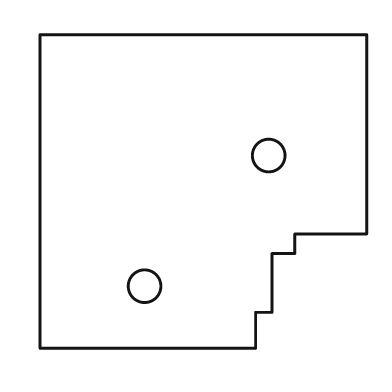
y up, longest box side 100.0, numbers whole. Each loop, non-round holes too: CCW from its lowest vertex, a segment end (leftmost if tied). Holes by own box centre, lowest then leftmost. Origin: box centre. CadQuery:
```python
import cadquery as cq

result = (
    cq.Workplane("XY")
    .moveTo(-50.0, -48.0)
    .lineTo(16.0, -48.0)
    .lineTo(16.0, -37.0)
    .lineTo(21.0, -37.0)
    .lineTo(21.0, -19.0)
    .lineTo(28.0, -19.0)
    .lineTo(28.0, -13.0)
    .lineTo(50.0, -13.0)
    .lineTo(50.0, 48.0)
    .lineTo(-50.0, 48.0)
    .close()
    .moveTo(-18.0, -29.0)
    .circle(5.0)
    .moveTo(20.0, 11.0)
    .circle(5.0)
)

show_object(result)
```